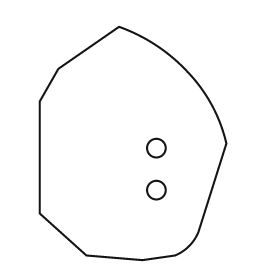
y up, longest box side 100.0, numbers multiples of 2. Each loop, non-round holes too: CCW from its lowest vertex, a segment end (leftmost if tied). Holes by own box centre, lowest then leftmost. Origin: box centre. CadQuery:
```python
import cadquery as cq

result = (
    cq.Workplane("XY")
    .moveTo(4.0, -50.0)
    .lineTo(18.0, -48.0)
    .threePointArc((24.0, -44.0), (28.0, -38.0))
    .lineTo(40.0, 0.0)
    .threePointArc((34.0, 16.0), (24.0, 30.0))
    .threePointArc((10.0, 42.0), (-6.0, 50.0))
    .lineTo(-32.0, 32.0)
    .lineTo(-40.0, 18.0)
    .lineTo(-40.0, -30.0)
    .lineTo(-20.0, -48.0)
    .close()
    .moveTo(10.0, -20.0)
    .circle(4.0)
    .moveTo(10.0, -2.0)
    .circle(4.0)
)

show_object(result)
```